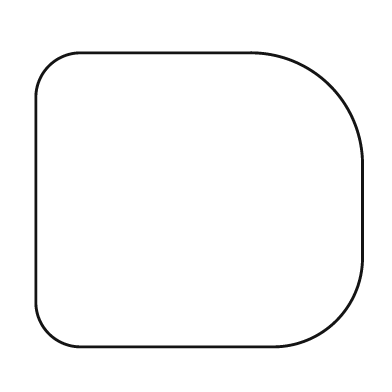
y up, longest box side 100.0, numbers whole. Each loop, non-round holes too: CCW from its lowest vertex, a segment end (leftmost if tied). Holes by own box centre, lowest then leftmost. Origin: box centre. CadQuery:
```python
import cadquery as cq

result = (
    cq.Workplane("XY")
    .moveTo(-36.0, -45.0)
    .lineTo(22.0, -45.0)
    .threePointArc((42.0, -37.0), (50.0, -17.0))
    .lineTo(50.0, 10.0)
    .threePointArc((40.0, 35.0), (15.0, 45.0))
    .lineTo(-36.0, 45.0)
    .threePointArc((-46.0, 41.0), (-50.0, 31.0))
    .lineTo(-50.0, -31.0)
    .threePointArc((-46.0, -41.0), (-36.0, -45.0))
    .close()
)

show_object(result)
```